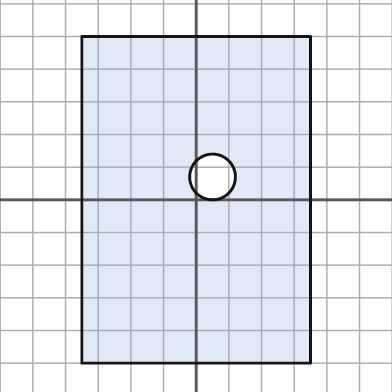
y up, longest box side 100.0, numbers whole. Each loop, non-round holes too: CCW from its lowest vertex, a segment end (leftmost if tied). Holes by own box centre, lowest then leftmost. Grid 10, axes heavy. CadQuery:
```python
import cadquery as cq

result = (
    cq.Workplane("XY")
    .moveTo(-35.0, -50.0)
    .lineTo(35.0, -50.0)
    .lineTo(35.0, 50.0)
    .lineTo(-35.0, 50.0)
    .close()
    .moveTo(5.0, 7.0)
    .circle(7.0)
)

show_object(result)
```